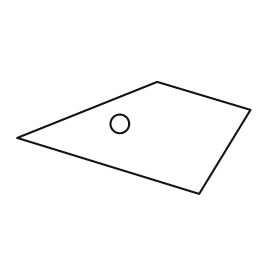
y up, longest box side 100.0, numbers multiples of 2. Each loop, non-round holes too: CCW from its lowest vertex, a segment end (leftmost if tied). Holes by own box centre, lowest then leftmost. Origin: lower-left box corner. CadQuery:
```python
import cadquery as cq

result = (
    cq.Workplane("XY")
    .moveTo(78.0, 0.0)
    .lineTo(100.0, 36.0)
    .lineTo(60.0, 48.0)
    .lineTo(0.0, 24.0)
    .close()
    .moveTo(44.0, 30.0)
    .circle(4.0)
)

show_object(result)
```